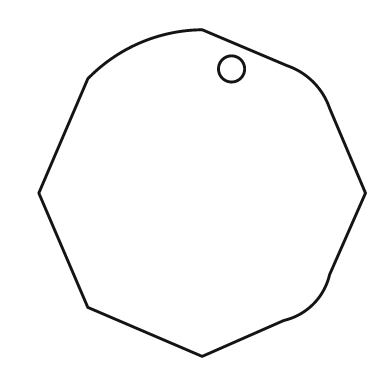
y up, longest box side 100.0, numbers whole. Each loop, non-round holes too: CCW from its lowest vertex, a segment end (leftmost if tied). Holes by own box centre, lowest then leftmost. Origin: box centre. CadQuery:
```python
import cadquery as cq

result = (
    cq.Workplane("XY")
    .moveTo(0.0, -50.0)
    .lineTo(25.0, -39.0)
    .threePointArc((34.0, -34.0), (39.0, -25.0))
    .lineTo(50.0, 0.0)
    .lineTo(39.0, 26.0)
    .threePointArc((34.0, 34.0), (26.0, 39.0))
    .lineTo(0.0, 50.0)
    .threePointArc((-19.0, 46.0), (-35.0, 35.0))
    .lineTo(-50.0, 0.0)
    .lineTo(-35.0, -35.0)
    .close()
    .moveTo(9.0, 38.0)
    .circle(4.0)
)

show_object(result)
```